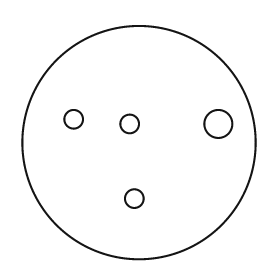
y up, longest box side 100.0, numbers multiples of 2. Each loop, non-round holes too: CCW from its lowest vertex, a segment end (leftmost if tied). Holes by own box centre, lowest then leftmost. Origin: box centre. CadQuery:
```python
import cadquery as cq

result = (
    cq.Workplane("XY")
    .moveTo(0.0, 0.0)
    .circle(50.0)
    .moveTo(-2.0, -24.0)
    .circle(4.0)
    .moveTo(-4.0, 8.0)
    .circle(4.0)
    .moveTo(34.0, 8.0)
    .circle(6.0)
    .moveTo(-28.0, 10.0)
    .circle(4.0)
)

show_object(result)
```